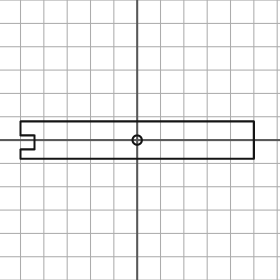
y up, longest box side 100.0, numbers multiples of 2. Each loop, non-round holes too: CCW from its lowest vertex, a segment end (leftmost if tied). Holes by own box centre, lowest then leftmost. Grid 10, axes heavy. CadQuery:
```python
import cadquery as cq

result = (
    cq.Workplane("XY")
    .moveTo(-50.0, -8.0)
    .lineTo(50.0, -8.0)
    .lineTo(50.0, 8.0)
    .lineTo(-50.0, 8.0)
    .lineTo(-50.0, 2.0)
    .lineTo(-44.0, 2.0)
    .lineTo(-44.0, -4.0)
    .lineTo(-50.0, -4.0)
    .close()
    .moveTo(0.0, 0.0)
    .circle(2.0)
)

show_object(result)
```